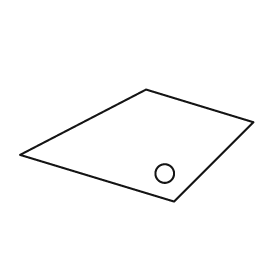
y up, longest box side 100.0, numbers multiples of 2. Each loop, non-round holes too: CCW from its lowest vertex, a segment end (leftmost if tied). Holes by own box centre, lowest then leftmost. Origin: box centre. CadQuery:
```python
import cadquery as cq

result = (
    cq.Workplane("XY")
    .moveTo(16.0, -24.0)
    .lineTo(50.0, 10.0)
    .lineTo(4.0, 24.0)
    .lineTo(-50.0, -4.0)
    .close()
    .moveTo(12.0, -12.0)
    .circle(4.0)
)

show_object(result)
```